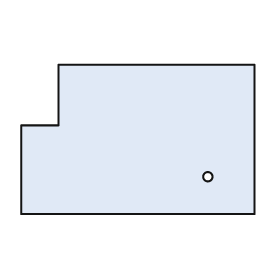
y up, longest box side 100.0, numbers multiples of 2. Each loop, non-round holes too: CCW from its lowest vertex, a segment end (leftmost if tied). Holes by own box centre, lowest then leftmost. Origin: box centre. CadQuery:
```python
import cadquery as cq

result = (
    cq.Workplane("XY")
    .moveTo(-50.0, -32.0)
    .lineTo(50.0, -32.0)
    .lineTo(50.0, 32.0)
    .lineTo(-34.0, 32.0)
    .lineTo(-34.0, 6.0)
    .lineTo(-50.0, 6.0)
    .close()
    .moveTo(30.0, -16.0)
    .circle(2.0)
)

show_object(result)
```